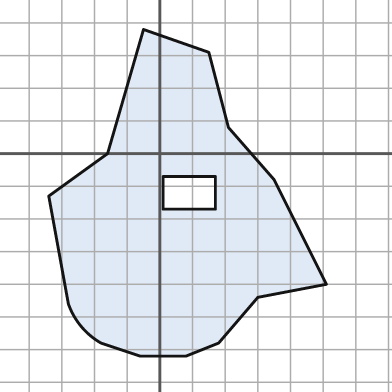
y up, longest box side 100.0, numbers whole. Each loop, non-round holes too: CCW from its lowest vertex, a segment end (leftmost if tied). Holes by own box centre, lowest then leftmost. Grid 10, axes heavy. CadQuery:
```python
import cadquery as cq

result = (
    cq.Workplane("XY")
    .moveTo(-6.0, -62.0)
    .lineTo(8.0, -62.0)
    .lineTo(18.0, -58.0)
    .lineTo(30.0, -44.0)
    .lineTo(51.0, -40.0)
    .lineTo(35.0, -8.0)
    .lineTo(21.0, 8.0)
    .lineTo(15.0, 31.0)
    .lineTo(-5.0, 38.0)
    .lineTo(-16.0, 0.0)
    .lineTo(-34.0, -13.0)
    .lineTo(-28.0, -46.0)
    .threePointArc((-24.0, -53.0), (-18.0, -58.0))
    .close()
    .moveTo(1.0, -17.0)
    .lineTo(17.0, -17.0)
    .lineTo(17.0, -7.0)
    .lineTo(1.0, -7.0)
    .close()
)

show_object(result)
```